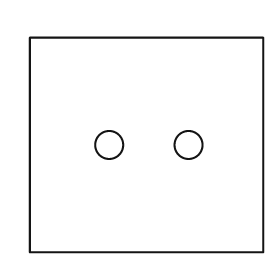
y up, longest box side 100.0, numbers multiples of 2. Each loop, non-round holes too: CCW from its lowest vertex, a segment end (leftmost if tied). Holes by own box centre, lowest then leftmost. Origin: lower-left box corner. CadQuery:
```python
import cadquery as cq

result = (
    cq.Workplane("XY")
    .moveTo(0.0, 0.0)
    .lineTo(100.0, 0.0)
    .lineTo(100.0, 92.0)
    .lineTo(0.0, 92.0)
    .close()
    .moveTo(34.0, 46.0)
    .circle(6.0)
    .moveTo(68.0, 46.0)
    .circle(6.0)
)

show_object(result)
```